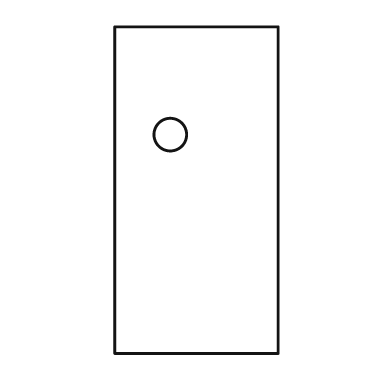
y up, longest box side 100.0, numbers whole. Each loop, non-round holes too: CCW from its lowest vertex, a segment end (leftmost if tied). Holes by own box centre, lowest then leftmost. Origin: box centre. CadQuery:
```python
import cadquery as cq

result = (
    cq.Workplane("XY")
    .moveTo(-25.0, -50.0)
    .lineTo(25.0, -50.0)
    .lineTo(25.0, 50.0)
    .lineTo(-25.0, 50.0)
    .close()
    .moveTo(-8.0, 17.0)
    .circle(5.0)
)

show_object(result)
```